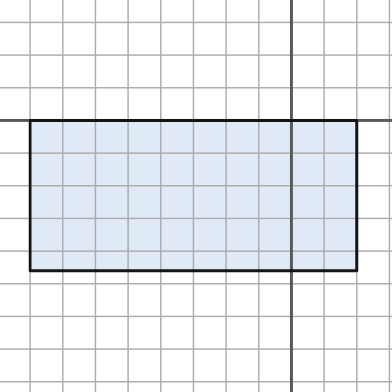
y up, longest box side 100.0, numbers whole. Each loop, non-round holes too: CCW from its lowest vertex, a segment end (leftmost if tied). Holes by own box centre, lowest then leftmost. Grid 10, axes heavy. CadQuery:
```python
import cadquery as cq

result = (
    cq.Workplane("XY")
    .moveTo(-80.0, -46.0)
    .lineTo(20.0, -46.0)
    .lineTo(20.0, 0.0)
    .lineTo(-80.0, 0.0)
    .close()
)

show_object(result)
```